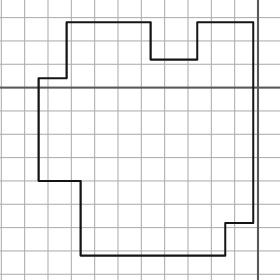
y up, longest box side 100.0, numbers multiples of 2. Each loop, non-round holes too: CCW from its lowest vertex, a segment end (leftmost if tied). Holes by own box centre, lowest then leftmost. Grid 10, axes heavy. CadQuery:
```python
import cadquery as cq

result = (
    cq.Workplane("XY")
    .moveTo(-76.0, -72.0)
    .lineTo(-14.0, -72.0)
    .lineTo(-14.0, -58.0)
    .lineTo(-2.0, -58.0)
    .lineTo(-2.0, 28.0)
    .lineTo(-26.0, 28.0)
    .lineTo(-26.0, 12.0)
    .lineTo(-46.0, 12.0)
    .lineTo(-46.0, 28.0)
    .lineTo(-82.0, 28.0)
    .lineTo(-82.0, 4.0)
    .lineTo(-94.0, 4.0)
    .lineTo(-94.0, -40.0)
    .lineTo(-76.0, -40.0)
    .close()
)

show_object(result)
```